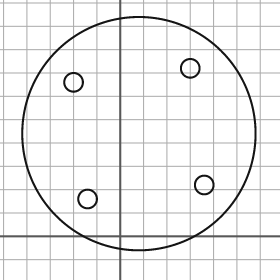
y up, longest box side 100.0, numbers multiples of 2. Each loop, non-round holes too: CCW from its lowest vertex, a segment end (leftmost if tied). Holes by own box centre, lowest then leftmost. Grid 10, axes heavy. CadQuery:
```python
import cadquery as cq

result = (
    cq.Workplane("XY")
    .moveTo(8.0, 44.0)
    .circle(50.0)
    .moveTo(-14.0, 16.0)
    .circle(4.0)
    .moveTo(36.0, 22.0)
    .circle(4.0)
    .moveTo(-20.0, 66.0)
    .circle(4.0)
    .moveTo(30.0, 72.0)
    .circle(4.0)
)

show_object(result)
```